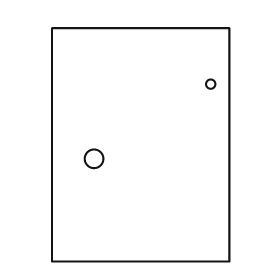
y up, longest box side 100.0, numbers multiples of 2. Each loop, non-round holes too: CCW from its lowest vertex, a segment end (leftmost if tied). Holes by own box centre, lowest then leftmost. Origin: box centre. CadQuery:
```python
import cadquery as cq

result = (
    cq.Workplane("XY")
    .moveTo(-38.0, -50.0)
    .lineTo(38.0, -50.0)
    .lineTo(38.0, 50.0)
    .lineTo(-38.0, 50.0)
    .close()
    .moveTo(-20.0, -6.0)
    .circle(4.0)
    .moveTo(30.0, 26.0)
    .circle(2.0)
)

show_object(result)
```